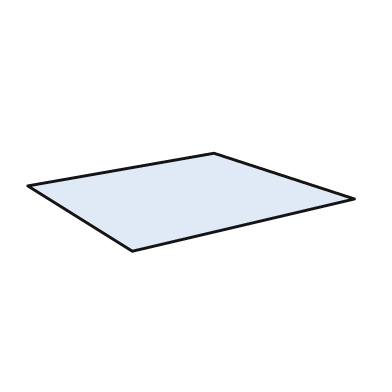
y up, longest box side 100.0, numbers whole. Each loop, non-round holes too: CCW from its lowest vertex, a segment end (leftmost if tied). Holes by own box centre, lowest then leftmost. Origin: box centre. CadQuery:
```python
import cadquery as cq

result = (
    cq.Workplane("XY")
    .moveTo(-18.0, -15.0)
    .lineTo(50.0, 1.0)
    .lineTo(7.0, 15.0)
    .lineTo(-50.0, 5.0)
    .close()
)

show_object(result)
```